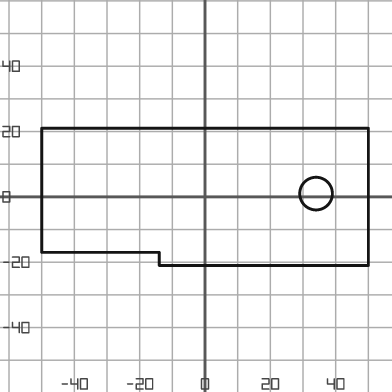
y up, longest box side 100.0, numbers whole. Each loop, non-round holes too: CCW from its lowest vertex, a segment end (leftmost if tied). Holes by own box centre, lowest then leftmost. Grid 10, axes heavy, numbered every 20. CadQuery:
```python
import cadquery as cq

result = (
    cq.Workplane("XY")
    .moveTo(-14.0, -21.0)
    .lineTo(50.0, -21.0)
    .lineTo(50.0, 21.0)
    .lineTo(-50.0, 21.0)
    .lineTo(-50.0, -17.0)
    .lineTo(-14.0, -17.0)
    .close()
    .moveTo(34.0, 1.0)
    .circle(5.0)
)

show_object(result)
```